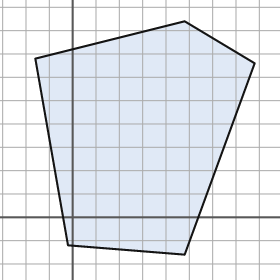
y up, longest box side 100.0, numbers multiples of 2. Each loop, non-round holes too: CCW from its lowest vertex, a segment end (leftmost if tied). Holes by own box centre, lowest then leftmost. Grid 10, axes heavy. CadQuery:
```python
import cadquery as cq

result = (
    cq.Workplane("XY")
    .moveTo(48.0, -16.0)
    .lineTo(78.0, 66.0)
    .lineTo(48.0, 84.0)
    .lineTo(-16.0, 68.0)
    .lineTo(-2.0, -12.0)
    .close()
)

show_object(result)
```